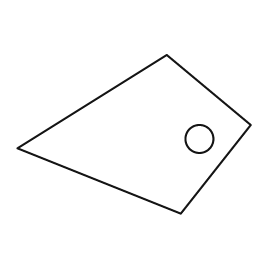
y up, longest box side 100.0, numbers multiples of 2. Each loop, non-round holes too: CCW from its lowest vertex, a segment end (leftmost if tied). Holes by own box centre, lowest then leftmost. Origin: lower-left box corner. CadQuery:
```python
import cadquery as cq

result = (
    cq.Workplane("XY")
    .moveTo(70.0, 0.0)
    .lineTo(100.0, 38.0)
    .lineTo(64.0, 68.0)
    .lineTo(0.0, 28.0)
    .close()
    .moveTo(78.0, 32.0)
    .circle(6.0)
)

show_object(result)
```